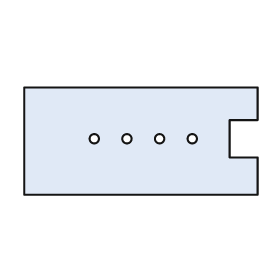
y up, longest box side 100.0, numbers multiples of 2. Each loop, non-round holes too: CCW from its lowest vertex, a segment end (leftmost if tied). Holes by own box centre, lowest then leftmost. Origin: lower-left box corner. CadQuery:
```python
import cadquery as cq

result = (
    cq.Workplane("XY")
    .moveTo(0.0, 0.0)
    .lineTo(100.0, 0.0)
    .lineTo(100.0, 16.0)
    .lineTo(88.0, 16.0)
    .lineTo(88.0, 32.0)
    .lineTo(100.0, 32.0)
    .lineTo(100.0, 46.0)
    .lineTo(0.0, 46.0)
    .close()
    .moveTo(30.0, 24.0)
    .circle(2.0)
    .moveTo(44.0, 24.0)
    .circle(2.0)
    .moveTo(58.0, 24.0)
    .circle(2.0)
    .moveTo(72.0, 24.0)
    .circle(2.0)
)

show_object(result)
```